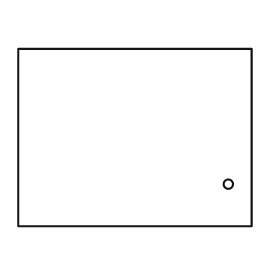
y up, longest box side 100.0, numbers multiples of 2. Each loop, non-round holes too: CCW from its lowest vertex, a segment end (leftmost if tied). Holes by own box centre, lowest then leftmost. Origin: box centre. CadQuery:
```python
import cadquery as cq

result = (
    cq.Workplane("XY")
    .moveTo(-50.0, -38.0)
    .lineTo(50.0, -38.0)
    .lineTo(50.0, 38.0)
    .lineTo(-50.0, 38.0)
    .close()
    .moveTo(40.0, -20.0)
    .circle(2.0)
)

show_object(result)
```